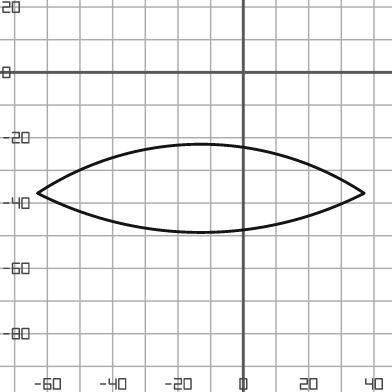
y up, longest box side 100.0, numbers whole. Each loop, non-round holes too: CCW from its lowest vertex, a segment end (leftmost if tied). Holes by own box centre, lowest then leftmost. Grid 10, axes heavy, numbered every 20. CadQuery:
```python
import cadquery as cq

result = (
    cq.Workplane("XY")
    .moveTo(-63.0, -37.0)
    .threePointArc((-13.0, -49.0), (37.0, -37.0))
    .threePointArc((-13.0, -22.0), (-63.0, -37.0))
    .close()
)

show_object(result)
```